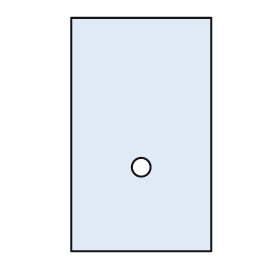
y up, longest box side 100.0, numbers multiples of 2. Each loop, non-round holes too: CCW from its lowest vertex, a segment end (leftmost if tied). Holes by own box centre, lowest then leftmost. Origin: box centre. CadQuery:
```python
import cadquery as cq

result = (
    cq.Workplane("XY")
    .moveTo(-30.0, -50.0)
    .lineTo(30.0, -50.0)
    .lineTo(30.0, 50.0)
    .lineTo(-30.0, 50.0)
    .close()
    .moveTo(0.0, -14.0)
    .circle(4.0)
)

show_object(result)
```